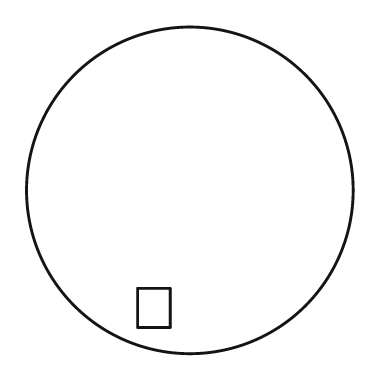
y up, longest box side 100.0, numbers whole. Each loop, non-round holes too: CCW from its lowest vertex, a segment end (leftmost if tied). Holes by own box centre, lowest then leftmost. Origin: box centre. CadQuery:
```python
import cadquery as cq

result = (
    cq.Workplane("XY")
    .moveTo(0.0, 0.0)
    .circle(50.0)
    .moveTo(-16.0, -42.0)
    .lineTo(-6.0, -42.0)
    .lineTo(-6.0, -30.0)
    .lineTo(-16.0, -30.0)
    .close()
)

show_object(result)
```